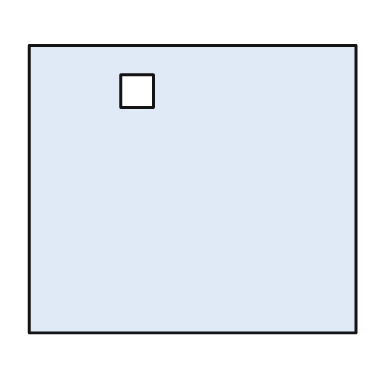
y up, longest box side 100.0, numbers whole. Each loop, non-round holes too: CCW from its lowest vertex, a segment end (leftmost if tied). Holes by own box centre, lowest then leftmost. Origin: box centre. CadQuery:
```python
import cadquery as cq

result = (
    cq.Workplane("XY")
    .moveTo(-50.0, -44.0)
    .lineTo(50.0, -44.0)
    .lineTo(50.0, 44.0)
    .lineTo(-50.0, 44.0)
    .close()
    .moveTo(-22.0, 25.0)
    .lineTo(-12.0, 25.0)
    .lineTo(-12.0, 35.0)
    .lineTo(-22.0, 35.0)
    .close()
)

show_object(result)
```